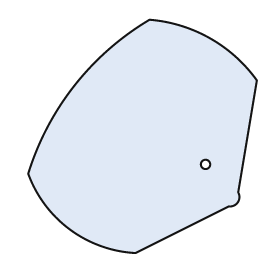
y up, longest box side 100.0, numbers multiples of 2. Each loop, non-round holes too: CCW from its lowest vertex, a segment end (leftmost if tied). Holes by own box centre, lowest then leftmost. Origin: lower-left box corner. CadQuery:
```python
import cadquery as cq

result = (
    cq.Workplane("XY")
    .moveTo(46.0, 0.0)
    .lineTo(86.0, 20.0)
    .threePointArc((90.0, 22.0), (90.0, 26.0))
    .lineTo(98.0, 74.0)
    .threePointArc((78.0, 92.0), (52.0, 100.0))
    .threePointArc((20.0, 72.0), (0.0, 34.0))
    .threePointArc((18.0, 10.0), (46.0, 0.0))
    .close()
    .moveTo(76.0, 38.0)
    .circle(2.0)
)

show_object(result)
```